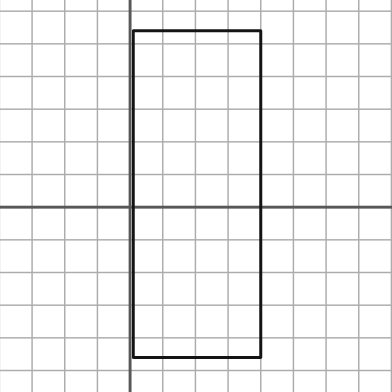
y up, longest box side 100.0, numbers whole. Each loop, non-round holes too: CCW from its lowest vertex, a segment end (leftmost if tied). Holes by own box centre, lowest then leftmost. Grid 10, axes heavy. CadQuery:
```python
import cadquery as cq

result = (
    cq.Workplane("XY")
    .moveTo(1.0, -46.0)
    .lineTo(40.0, -46.0)
    .lineTo(40.0, 54.0)
    .lineTo(1.0, 54.0)
    .close()
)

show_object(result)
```